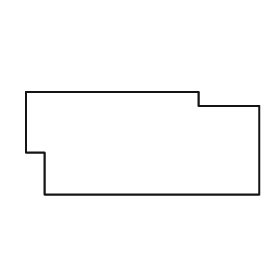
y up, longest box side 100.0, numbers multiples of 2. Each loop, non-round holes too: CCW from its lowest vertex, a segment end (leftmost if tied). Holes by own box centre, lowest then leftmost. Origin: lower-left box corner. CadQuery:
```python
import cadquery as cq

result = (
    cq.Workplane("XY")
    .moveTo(8.0, 0.0)
    .lineTo(100.0, 0.0)
    .lineTo(100.0, 38.0)
    .lineTo(74.0, 38.0)
    .lineTo(74.0, 44.0)
    .lineTo(0.0, 44.0)
    .lineTo(0.0, 18.0)
    .lineTo(8.0, 18.0)
    .close()
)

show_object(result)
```